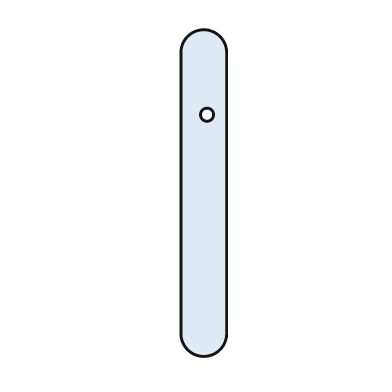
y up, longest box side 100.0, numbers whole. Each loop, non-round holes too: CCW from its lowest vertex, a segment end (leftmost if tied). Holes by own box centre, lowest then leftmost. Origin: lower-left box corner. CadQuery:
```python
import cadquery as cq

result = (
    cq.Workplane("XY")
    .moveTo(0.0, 7.0)
    .threePointArc((7.0, 0.0), (14.0, 7.0))
    .lineTo(14.0, 93.0)
    .threePointArc((7.0, 100.0), (0.0, 93.0))
    .close()
    .moveTo(8.0, 74.0)
    .circle(2.0)
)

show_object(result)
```